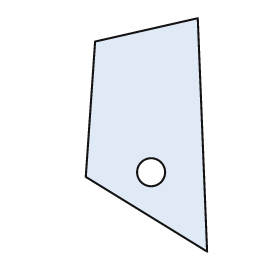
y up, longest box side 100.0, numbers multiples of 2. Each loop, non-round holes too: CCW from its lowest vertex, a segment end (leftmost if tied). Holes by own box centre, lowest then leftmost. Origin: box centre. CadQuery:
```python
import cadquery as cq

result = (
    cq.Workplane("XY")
    .moveTo(26.0, -50.0)
    .lineTo(22.0, 50.0)
    .lineTo(-22.0, 40.0)
    .lineTo(-26.0, -18.0)
    .close()
    .moveTo(2.0, -16.0)
    .circle(6.0)
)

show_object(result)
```